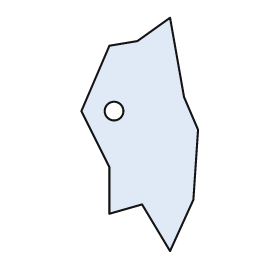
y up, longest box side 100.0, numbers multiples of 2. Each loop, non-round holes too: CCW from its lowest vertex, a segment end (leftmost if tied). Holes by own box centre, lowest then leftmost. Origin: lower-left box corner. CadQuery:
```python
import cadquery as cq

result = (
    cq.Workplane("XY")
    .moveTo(38.0, 0.0)
    .lineTo(48.0, 22.0)
    .lineTo(50.0, 52.0)
    .lineTo(44.0, 66.0)
    .lineTo(38.0, 100.0)
    .lineTo(24.0, 90.0)
    .lineTo(12.0, 88.0)
    .lineTo(0.0, 60.0)
    .lineTo(12.0, 36.0)
    .lineTo(12.0, 16.0)
    .lineTo(26.0, 20.0)
    .close()
    .moveTo(14.0, 60.0)
    .circle(4.0)
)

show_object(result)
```